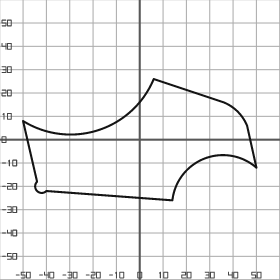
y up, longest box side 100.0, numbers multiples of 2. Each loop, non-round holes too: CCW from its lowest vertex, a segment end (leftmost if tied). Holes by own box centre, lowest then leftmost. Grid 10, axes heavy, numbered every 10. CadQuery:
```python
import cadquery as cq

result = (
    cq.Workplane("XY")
    .moveTo(14.0, -26.0)
    .threePointArc((28.0, -8.0), (50.0, -12.0))
    .lineTo(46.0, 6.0)
    .threePointArc((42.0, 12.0), (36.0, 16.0))
    .lineTo(6.0, 26.0)
    .threePointArc((-18.0, 4.0), (-50.0, 8.0))
    .lineTo(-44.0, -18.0)
    .threePointArc((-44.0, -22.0), (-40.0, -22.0))
    .close()
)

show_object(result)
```